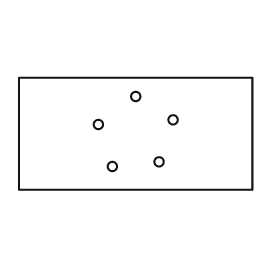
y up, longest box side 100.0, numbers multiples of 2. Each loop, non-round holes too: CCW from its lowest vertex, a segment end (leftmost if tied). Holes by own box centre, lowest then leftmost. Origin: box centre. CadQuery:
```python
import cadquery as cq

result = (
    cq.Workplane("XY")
    .moveTo(-50.0, -24.0)
    .lineTo(50.0, -24.0)
    .lineTo(50.0, 24.0)
    .lineTo(-50.0, 24.0)
    .close()
    .moveTo(-10.0, -14.0)
    .circle(2.0)
    .moveTo(10.0, -12.0)
    .circle(2.0)
    .moveTo(-16.0, 4.0)
    .circle(2.0)
    .moveTo(16.0, 6.0)
    .circle(2.0)
    .moveTo(0.0, 16.0)
    .circle(2.0)
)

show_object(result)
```